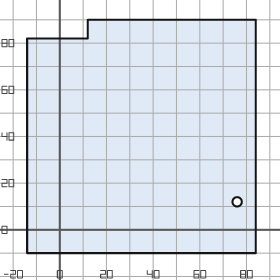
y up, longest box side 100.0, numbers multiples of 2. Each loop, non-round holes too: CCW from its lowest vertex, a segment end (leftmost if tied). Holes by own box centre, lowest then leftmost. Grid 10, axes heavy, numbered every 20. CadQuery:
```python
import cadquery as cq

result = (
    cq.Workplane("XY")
    .moveTo(-14.0, -10.0)
    .lineTo(84.0, -10.0)
    .lineTo(84.0, 90.0)
    .lineTo(12.0, 90.0)
    .lineTo(12.0, 82.0)
    .lineTo(-14.0, 82.0)
    .close()
    .moveTo(76.0, 12.0)
    .circle(2.0)
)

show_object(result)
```